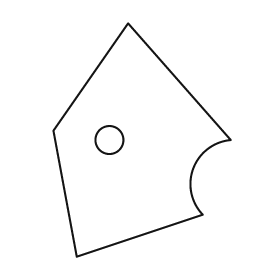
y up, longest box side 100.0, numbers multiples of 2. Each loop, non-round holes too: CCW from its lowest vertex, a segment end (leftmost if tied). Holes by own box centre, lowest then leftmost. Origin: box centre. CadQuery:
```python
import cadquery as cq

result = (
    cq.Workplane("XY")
    .moveTo(-28.0, -50.0)
    .lineTo(26.0, -32.0)
    .threePointArc((22.0, -12.0), (38.0, 0.0))
    .lineTo(-6.0, 50.0)
    .lineTo(-38.0, 4.0)
    .close()
    .moveTo(-14.0, 0.0)
    .circle(6.0)
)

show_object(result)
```